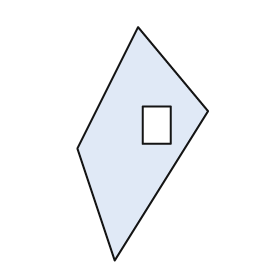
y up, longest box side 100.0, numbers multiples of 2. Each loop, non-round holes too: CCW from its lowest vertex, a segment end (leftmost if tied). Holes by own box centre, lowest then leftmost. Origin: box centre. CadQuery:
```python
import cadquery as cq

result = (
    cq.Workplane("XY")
    .moveTo(-12.0, -50.0)
    .lineTo(28.0, 14.0)
    .lineTo(-2.0, 50.0)
    .lineTo(-28.0, -2.0)
    .close()
    .moveTo(0.0, 0.0)
    .lineTo(12.0, 0.0)
    .lineTo(12.0, 16.0)
    .lineTo(0.0, 16.0)
    .close()
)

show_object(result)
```